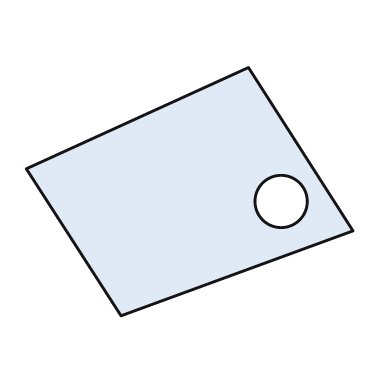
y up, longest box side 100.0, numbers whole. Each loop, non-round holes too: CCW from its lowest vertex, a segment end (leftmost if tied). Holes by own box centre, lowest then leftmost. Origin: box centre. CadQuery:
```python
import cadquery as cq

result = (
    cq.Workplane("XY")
    .moveTo(-21.0, -38.0)
    .lineTo(50.0, -12.0)
    .lineTo(18.0, 38.0)
    .lineTo(-50.0, 7.0)
    .close()
    .moveTo(28.0, -3.0)
    .circle(8.0)
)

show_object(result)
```